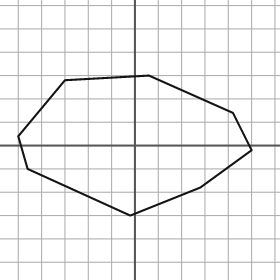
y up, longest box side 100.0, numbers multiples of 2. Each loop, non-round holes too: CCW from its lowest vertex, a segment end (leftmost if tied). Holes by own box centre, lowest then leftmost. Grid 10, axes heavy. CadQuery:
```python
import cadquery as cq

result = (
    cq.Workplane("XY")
    .moveTo(-2.0, -30.0)
    .lineTo(28.0, -18.0)
    .lineTo(50.0, -2.0)
    .lineTo(42.0, 14.0)
    .lineTo(6.0, 30.0)
    .lineTo(-30.0, 28.0)
    .lineTo(-50.0, 4.0)
    .lineTo(-46.0, -10.0)
    .close()
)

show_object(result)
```